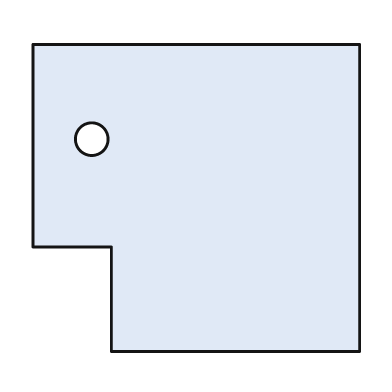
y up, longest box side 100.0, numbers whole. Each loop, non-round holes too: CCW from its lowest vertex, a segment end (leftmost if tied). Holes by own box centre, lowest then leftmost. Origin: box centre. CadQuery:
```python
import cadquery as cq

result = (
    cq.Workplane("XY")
    .moveTo(-26.0, -47.0)
    .lineTo(50.0, -47.0)
    .lineTo(50.0, 47.0)
    .lineTo(-50.0, 47.0)
    .lineTo(-50.0, -15.0)
    .lineTo(-26.0, -15.0)
    .close()
    .moveTo(-32.0, 18.0)
    .circle(5.0)
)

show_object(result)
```